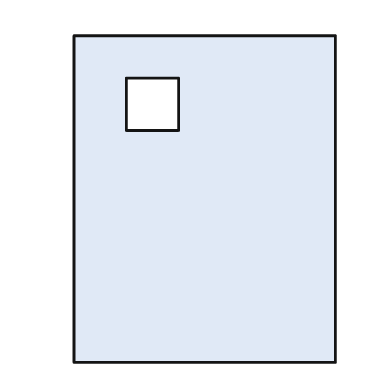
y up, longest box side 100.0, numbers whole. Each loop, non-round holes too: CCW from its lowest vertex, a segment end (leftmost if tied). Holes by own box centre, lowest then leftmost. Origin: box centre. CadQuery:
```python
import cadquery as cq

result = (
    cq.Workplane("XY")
    .moveTo(-40.0, -50.0)
    .lineTo(40.0, -50.0)
    .lineTo(40.0, 50.0)
    .lineTo(-40.0, 50.0)
    .close()
    .moveTo(-24.0, 21.0)
    .lineTo(-8.0, 21.0)
    .lineTo(-8.0, 37.0)
    .lineTo(-24.0, 37.0)
    .close()
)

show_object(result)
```